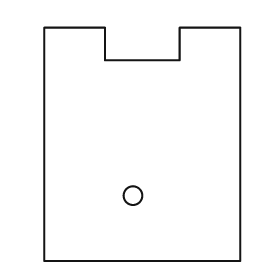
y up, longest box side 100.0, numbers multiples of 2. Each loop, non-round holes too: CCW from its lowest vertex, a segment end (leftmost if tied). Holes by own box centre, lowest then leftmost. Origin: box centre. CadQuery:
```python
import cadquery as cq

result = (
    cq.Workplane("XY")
    .moveTo(-42.0, -50.0)
    .lineTo(42.0, -50.0)
    .lineTo(42.0, 50.0)
    .lineTo(16.0, 50.0)
    .lineTo(16.0, 36.0)
    .lineTo(-16.0, 36.0)
    .lineTo(-16.0, 50.0)
    .lineTo(-42.0, 50.0)
    .close()
    .moveTo(-4.0, -22.0)
    .circle(4.0)
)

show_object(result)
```